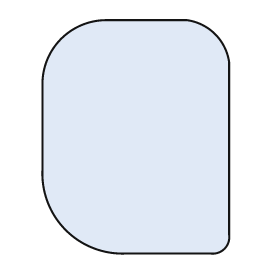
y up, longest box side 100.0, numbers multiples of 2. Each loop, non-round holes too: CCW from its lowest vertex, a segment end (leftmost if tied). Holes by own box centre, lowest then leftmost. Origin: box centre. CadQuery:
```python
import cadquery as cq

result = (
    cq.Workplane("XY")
    .moveTo(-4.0, -50.0)
    .lineTo(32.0, -50.0)
    .threePointArc((38.0, -48.0), (40.0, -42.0))
    .lineTo(40.0, 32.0)
    .threePointArc((34.0, 44.0), (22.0, 50.0))
    .lineTo(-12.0, 50.0)
    .threePointArc((-32.0, 42.0), (-40.0, 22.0))
    .lineTo(-40.0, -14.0)
    .threePointArc((-30.0, -40.0), (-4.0, -50.0))
    .close()
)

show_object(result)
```